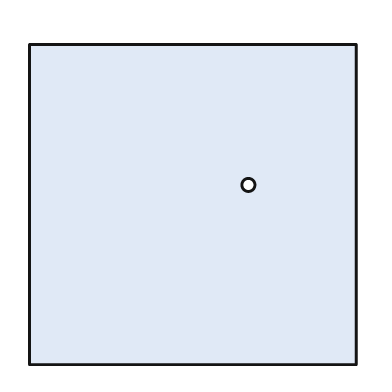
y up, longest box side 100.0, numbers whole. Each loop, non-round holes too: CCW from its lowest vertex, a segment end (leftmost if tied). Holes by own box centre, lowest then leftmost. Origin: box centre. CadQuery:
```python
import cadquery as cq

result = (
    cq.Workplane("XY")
    .moveTo(-50.0, -49.0)
    .lineTo(50.0, -49.0)
    .lineTo(50.0, 49.0)
    .lineTo(-50.0, 49.0)
    .close()
    .moveTo(17.0, 6.0)
    .circle(2.0)
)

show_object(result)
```